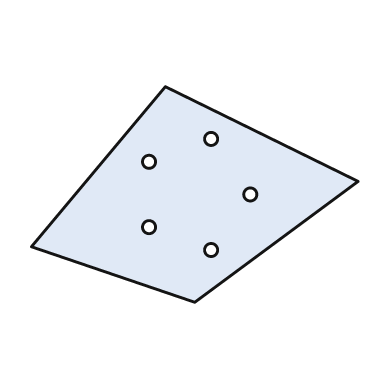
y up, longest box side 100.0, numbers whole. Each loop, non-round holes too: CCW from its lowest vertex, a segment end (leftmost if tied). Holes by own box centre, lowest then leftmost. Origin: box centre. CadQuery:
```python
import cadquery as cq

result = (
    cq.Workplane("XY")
    .moveTo(0.0, -33.0)
    .lineTo(50.0, 4.0)
    .lineTo(-9.0, 33.0)
    .lineTo(-50.0, -16.0)
    .close()
    .moveTo(5.0, -17.0)
    .circle(2.0)
    .moveTo(-14.0, -10.0)
    .circle(2.0)
    .moveTo(17.0, 0.0)
    .circle(2.0)
    .moveTo(-14.0, 10.0)
    .circle(2.0)
    .moveTo(5.0, 17.0)
    .circle(2.0)
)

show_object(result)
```